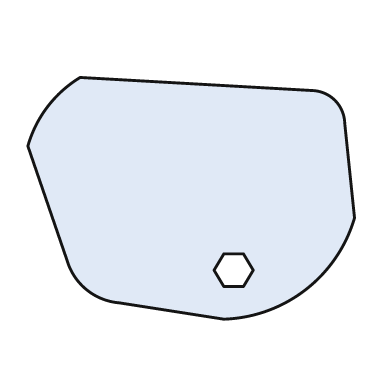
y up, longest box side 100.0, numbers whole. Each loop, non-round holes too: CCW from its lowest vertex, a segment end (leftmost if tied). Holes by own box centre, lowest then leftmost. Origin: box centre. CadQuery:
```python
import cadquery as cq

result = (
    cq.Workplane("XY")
    .moveTo(10.0, -37.0)
    .threePointArc((35.0, -28.0), (50.0, -6.0))
    .lineTo(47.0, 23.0)
    .threePointArc((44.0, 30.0), (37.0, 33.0))
    .lineTo(-34.0, 37.0)
    .threePointArc((-44.0, 28.0), (-50.0, 16.0))
    .lineTo(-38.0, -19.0)
    .threePointArc((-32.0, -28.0), (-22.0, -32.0))
    .close()
    .moveTo(10.0, -27.0)
    .lineTo(16.0, -27.0)
    .lineTo(19.0, -22.0)
    .lineTo(16.0, -17.0)
    .lineTo(10.0, -17.0)
    .lineTo(7.0, -22.0)
    .close()
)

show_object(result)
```